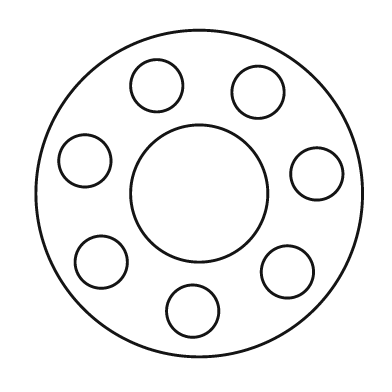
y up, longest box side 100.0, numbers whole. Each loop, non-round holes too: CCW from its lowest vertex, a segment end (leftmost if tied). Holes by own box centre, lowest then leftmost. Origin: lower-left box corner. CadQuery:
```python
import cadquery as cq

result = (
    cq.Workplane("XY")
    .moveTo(50.0, 50.0)
    .circle(50.0)
    .moveTo(48.0, 14.0)
    .circle(8.0)
    .moveTo(77.0, 26.0)
    .circle(8.0)
    .moveTo(20.0, 29.0)
    .circle(8.0)
    .moveTo(50.0, 50.0)
    .circle(21.0)
    .moveTo(86.0, 56.0)
    .circle(8.0)
    .moveTo(15.0, 60.0)
    .circle(8.0)
    .moveTo(68.0, 81.0)
    .circle(8.0)
    .moveTo(37.0, 83.0)
    .circle(8.0)
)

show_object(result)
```